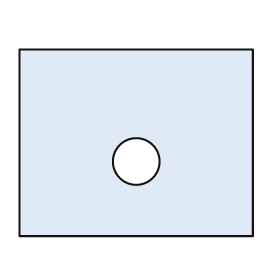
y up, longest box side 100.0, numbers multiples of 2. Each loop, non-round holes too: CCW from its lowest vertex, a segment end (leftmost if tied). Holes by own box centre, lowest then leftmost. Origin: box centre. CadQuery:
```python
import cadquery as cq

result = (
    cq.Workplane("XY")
    .moveTo(-50.0, -40.0)
    .lineTo(50.0, -40.0)
    .lineTo(50.0, 40.0)
    .lineTo(-50.0, 40.0)
    .close()
    .moveTo(0.0, -8.0)
    .circle(10.0)
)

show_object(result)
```